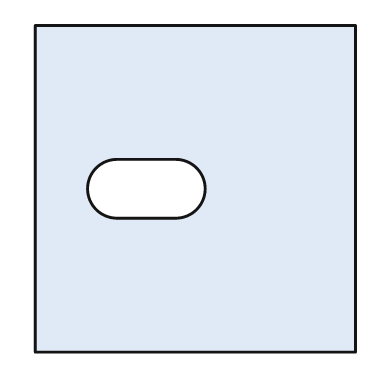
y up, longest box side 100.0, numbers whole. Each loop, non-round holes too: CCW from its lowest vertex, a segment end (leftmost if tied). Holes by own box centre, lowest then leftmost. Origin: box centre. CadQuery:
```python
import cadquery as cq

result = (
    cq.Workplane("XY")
    .moveTo(-49.0, -50.0)
    .lineTo(49.0, -50.0)
    .lineTo(49.0, 50.0)
    .lineTo(-49.0, 50.0)
    .close()
    .moveTo(-24.0, -9.0)
    .lineTo(-6.0, -9.0)
    .threePointArc((3.0, 0.0), (-6.0, 9.0))
    .lineTo(-24.0, 9.0)
    .threePointArc((-33.0, 0.0), (-24.0, -9.0))
    .close()
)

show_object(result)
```